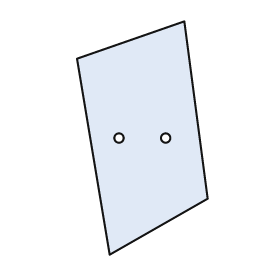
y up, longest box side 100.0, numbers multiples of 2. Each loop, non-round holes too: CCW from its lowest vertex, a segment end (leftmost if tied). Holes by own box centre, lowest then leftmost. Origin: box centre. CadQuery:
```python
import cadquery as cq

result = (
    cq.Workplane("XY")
    .moveTo(-14.0, -50.0)
    .lineTo(28.0, -26.0)
    .lineTo(18.0, 50.0)
    .lineTo(-28.0, 34.0)
    .close()
    .moveTo(-10.0, 0.0)
    .circle(2.0)
    .moveTo(10.0, 0.0)
    .circle(2.0)
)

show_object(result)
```